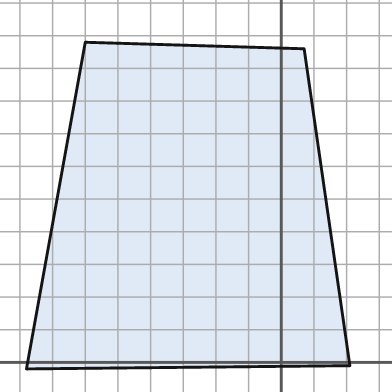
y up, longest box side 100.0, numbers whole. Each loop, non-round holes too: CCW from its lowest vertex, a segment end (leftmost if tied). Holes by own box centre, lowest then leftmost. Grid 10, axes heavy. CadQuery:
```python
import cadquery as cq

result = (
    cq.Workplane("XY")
    .moveTo(-78.0, -2.0)
    .lineTo(21.0, -1.0)
    .lineTo(7.0, 96.0)
    .lineTo(-60.0, 98.0)
    .close()
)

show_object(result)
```